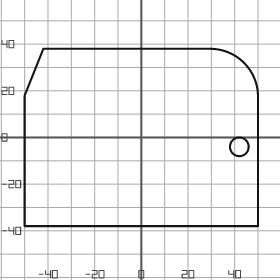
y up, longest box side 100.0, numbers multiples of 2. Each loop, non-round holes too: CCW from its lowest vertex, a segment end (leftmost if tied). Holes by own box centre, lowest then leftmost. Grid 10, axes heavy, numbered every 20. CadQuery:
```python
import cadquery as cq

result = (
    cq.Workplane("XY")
    .moveTo(-50.0, -38.0)
    .lineTo(50.0, -38.0)
    .lineTo(50.0, 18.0)
    .threePointArc((44.0, 32.0), (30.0, 38.0))
    .lineTo(-42.0, 38.0)
    .lineTo(-50.0, 18.0)
    .close()
    .moveTo(42.0, -4.0)
    .circle(4.0)
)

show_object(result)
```